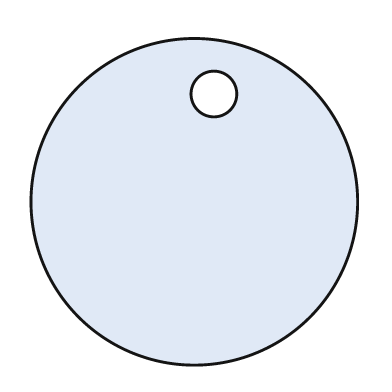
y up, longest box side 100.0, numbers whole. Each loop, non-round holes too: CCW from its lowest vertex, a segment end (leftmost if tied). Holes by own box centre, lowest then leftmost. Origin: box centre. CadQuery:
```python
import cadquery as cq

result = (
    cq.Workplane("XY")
    .moveTo(0.0, 0.0)
    .circle(50.0)
    .moveTo(6.0, 33.0)
    .circle(7.0)
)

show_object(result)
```